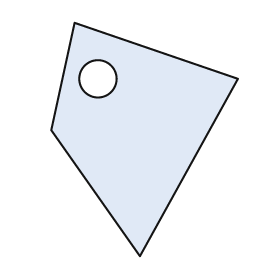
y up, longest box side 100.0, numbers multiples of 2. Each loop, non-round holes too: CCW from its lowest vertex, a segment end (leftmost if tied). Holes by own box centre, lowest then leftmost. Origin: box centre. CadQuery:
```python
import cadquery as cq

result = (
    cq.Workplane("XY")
    .moveTo(-2.0, -50.0)
    .lineTo(40.0, 26.0)
    .lineTo(-30.0, 50.0)
    .lineTo(-40.0, 4.0)
    .close()
    .moveTo(-20.0, 26.0)
    .circle(8.0)
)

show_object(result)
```